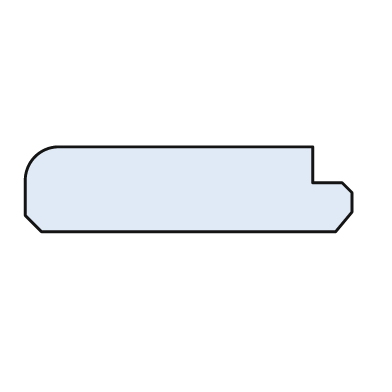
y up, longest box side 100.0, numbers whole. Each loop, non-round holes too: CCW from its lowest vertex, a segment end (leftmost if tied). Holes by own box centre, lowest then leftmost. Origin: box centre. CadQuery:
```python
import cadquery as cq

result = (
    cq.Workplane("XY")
    .moveTo(-45.0, -13.0)
    .lineTo(45.0, -13.0)
    .lineTo(50.0, -7.0)
    .lineTo(50.0, -1.0)
    .lineTo(47.0, 2.0)
    .lineTo(38.0, 2.0)
    .lineTo(38.0, 13.0)
    .lineTo(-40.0, 13.0)
    .threePointArc((-47.0, 10.0), (-50.0, 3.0))
    .lineTo(-50.0, -8.0)
    .close()
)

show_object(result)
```